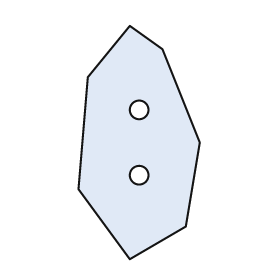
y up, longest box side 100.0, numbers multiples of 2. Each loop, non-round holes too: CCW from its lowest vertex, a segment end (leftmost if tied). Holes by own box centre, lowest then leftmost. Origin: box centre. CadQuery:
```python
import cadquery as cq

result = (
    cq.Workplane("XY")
    .moveTo(-4.0, -50.0)
    .lineTo(20.0, -36.0)
    .lineTo(26.0, 0.0)
    .lineTo(10.0, 40.0)
    .lineTo(-4.0, 50.0)
    .lineTo(-22.0, 28.0)
    .lineTo(-26.0, -20.0)
    .close()
    .moveTo(0.0, -14.0)
    .circle(4.0)
    .moveTo(0.0, 14.0)
    .circle(4.0)
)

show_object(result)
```